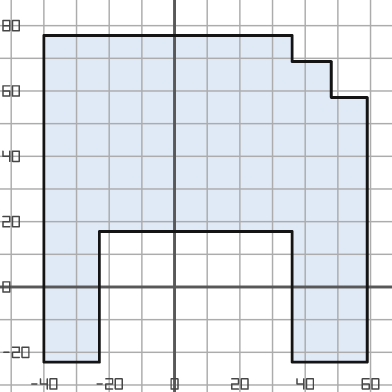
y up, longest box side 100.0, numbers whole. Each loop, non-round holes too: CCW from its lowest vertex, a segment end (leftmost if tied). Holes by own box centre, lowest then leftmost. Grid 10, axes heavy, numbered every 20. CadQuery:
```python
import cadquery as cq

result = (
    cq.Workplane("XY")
    .moveTo(-40.0, -23.0)
    .lineTo(-23.0, -23.0)
    .lineTo(-23.0, 17.0)
    .lineTo(36.0, 17.0)
    .lineTo(36.0, -23.0)
    .lineTo(59.0, -23.0)
    .lineTo(59.0, 58.0)
    .lineTo(48.0, 58.0)
    .lineTo(48.0, 69.0)
    .lineTo(36.0, 69.0)
    .lineTo(36.0, 77.0)
    .lineTo(-40.0, 77.0)
    .close()
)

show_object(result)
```